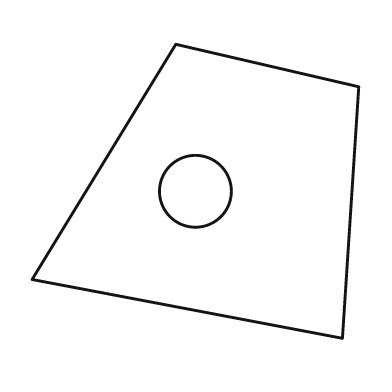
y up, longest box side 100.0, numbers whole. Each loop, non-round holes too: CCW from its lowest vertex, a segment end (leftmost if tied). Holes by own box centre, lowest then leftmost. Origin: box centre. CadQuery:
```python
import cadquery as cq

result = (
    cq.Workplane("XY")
    .moveTo(45.0, -45.0)
    .lineTo(50.0, 32.0)
    .lineTo(-6.0, 45.0)
    .lineTo(-50.0, -27.0)
    .close()
    .moveTo(0.0, 0.0)
    .circle(11.0)
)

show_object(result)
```